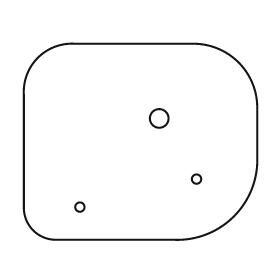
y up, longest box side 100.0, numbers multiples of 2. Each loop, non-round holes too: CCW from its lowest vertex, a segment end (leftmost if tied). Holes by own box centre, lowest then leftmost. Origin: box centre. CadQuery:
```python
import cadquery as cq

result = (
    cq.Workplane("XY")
    .moveTo(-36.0, -42.0)
    .lineTo(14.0, -42.0)
    .threePointArc((40.0, -32.0), (50.0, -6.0))
    .lineTo(50.0, 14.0)
    .threePointArc((42.0, 34.0), (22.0, 42.0))
    .lineTo(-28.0, 42.0)
    .threePointArc((-44.0, 36.0), (-50.0, 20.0))
    .lineTo(-50.0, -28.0)
    .threePointArc((-46.0, -38.0), (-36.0, -42.0))
    .close()
    .moveTo(-26.0, -28.0)
    .circle(2.0)
    .moveTo(24.0, -16.0)
    .circle(2.0)
    .moveTo(8.0, 10.0)
    .circle(4.0)
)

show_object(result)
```